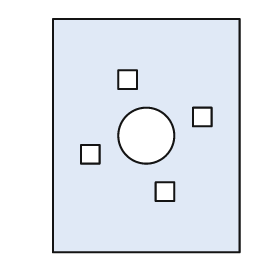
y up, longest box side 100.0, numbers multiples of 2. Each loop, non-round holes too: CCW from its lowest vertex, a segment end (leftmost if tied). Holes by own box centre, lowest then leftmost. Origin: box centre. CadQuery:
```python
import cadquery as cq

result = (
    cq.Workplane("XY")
    .moveTo(-40.0, -50.0)
    .lineTo(40.0, -50.0)
    .lineTo(40.0, 50.0)
    .lineTo(-40.0, 50.0)
    .close()
    .moveTo(4.0, -28.0)
    .lineTo(12.0, -28.0)
    .lineTo(12.0, -20.0)
    .lineTo(4.0, -20.0)
    .close()
    .moveTo(-28.0, -12.0)
    .lineTo(-20.0, -12.0)
    .lineTo(-20.0, -4.0)
    .lineTo(-28.0, -4.0)
    .close()
    .moveTo(0.0, 0.0)
    .circle(12.0)
    .moveTo(20.0, 4.0)
    .lineTo(28.0, 4.0)
    .lineTo(28.0, 12.0)
    .lineTo(20.0, 12.0)
    .close()
    .moveTo(-12.0, 20.0)
    .lineTo(-4.0, 20.0)
    .lineTo(-4.0, 28.0)
    .lineTo(-12.0, 28.0)
    .close()
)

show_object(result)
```